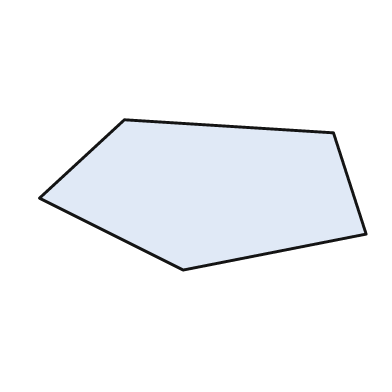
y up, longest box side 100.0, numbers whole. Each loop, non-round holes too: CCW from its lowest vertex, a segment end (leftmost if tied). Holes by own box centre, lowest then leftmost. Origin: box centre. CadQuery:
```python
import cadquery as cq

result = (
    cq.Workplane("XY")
    .moveTo(-6.0, -23.0)
    .lineTo(50.0, -12.0)
    .lineTo(40.0, 19.0)
    .lineTo(-24.0, 23.0)
    .lineTo(-50.0, -1.0)
    .close()
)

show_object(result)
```